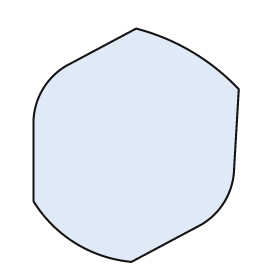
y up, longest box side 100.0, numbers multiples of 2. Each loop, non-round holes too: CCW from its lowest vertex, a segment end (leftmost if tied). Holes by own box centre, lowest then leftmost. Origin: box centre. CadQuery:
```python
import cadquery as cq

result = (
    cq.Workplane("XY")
    .moveTo(-2.0, -50.0)
    .lineTo(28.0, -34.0)
    .threePointArc((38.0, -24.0), (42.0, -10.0))
    .lineTo(44.0, 24.0)
    .threePointArc((24.0, 40.0), (0.0, 50.0))
    .lineTo(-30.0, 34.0)
    .threePointArc((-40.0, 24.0), (-44.0, 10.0))
    .lineTo(-44.0, -24.0)
    .threePointArc((-26.0, -42.0), (-2.0, -50.0))
    .close()
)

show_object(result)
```